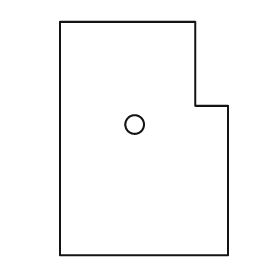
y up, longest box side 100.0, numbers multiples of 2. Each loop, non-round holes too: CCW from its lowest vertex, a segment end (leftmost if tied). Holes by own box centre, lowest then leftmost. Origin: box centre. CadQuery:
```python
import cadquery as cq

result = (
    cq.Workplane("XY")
    .moveTo(-36.0, -50.0)
    .lineTo(36.0, -50.0)
    .lineTo(36.0, 14.0)
    .lineTo(22.0, 14.0)
    .lineTo(22.0, 50.0)
    .lineTo(-36.0, 50.0)
    .close()
    .moveTo(-4.0, 6.0)
    .circle(4.0)
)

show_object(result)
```